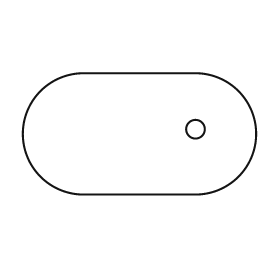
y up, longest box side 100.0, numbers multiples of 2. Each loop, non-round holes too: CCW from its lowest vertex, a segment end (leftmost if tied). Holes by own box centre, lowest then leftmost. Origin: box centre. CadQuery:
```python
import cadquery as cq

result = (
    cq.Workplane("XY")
    .moveTo(-24.0, -26.0)
    .lineTo(24.0, -26.0)
    .threePointArc((50.0, 0.0), (24.0, 26.0))
    .lineTo(-24.0, 26.0)
    .threePointArc((-50.0, 0.0), (-24.0, -26.0))
    .close()
    .moveTo(24.0, 2.0)
    .circle(4.0)
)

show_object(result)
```